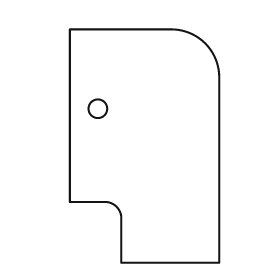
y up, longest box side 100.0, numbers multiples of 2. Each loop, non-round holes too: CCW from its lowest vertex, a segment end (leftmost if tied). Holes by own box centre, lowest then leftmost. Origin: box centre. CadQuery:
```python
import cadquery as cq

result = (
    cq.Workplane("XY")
    .moveTo(-10.0, -50.0)
    .lineTo(32.0, -50.0)
    .lineTo(32.0, 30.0)
    .threePointArc((26.0, 44.0), (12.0, 50.0))
    .lineTo(-32.0, 50.0)
    .lineTo(-32.0, -24.0)
    .lineTo(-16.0, -24.0)
    .threePointArc((-12.0, -26.0), (-10.0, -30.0))
    .close()
    .moveTo(-20.0, 16.0)
    .circle(4.0)
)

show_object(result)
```